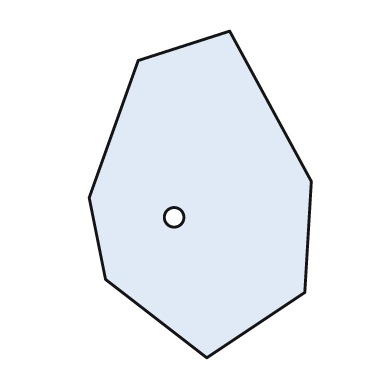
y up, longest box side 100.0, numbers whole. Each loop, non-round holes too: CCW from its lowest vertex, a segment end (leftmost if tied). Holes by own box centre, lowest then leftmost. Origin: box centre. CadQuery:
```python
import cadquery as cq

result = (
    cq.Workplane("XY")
    .moveTo(2.0, -50.0)
    .lineTo(32.0, -30.0)
    .lineTo(34.0, 4.0)
    .lineTo(9.0, 50.0)
    .lineTo(-19.0, 41.0)
    .lineTo(-34.0, -1.0)
    .lineTo(-29.0, -26.0)
    .close()
    .moveTo(-8.0, -7.0)
    .circle(3.0)
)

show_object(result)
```